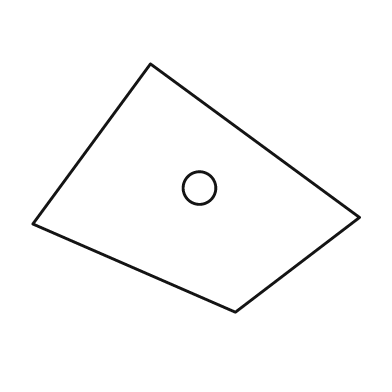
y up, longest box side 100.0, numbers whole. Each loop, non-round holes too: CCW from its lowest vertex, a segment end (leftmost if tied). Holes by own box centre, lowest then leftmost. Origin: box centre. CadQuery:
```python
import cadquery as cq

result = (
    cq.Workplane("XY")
    .moveTo(12.0, -38.0)
    .lineTo(50.0, -9.0)
    .lineTo(-14.0, 38.0)
    .lineTo(-50.0, -11.0)
    .close()
    .moveTo(1.0, 0.0)
    .circle(5.0)
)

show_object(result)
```